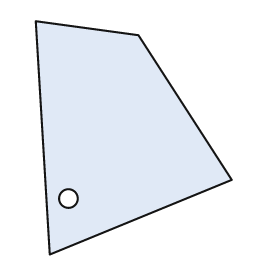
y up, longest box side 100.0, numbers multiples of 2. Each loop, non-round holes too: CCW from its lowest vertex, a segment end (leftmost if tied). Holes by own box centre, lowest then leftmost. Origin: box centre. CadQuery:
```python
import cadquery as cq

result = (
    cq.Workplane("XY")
    .moveTo(-36.0, -50.0)
    .lineTo(42.0, -18.0)
    .lineTo(2.0, 44.0)
    .lineTo(-42.0, 50.0)
    .close()
    .moveTo(-28.0, -26.0)
    .circle(4.0)
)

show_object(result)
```